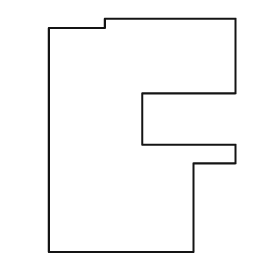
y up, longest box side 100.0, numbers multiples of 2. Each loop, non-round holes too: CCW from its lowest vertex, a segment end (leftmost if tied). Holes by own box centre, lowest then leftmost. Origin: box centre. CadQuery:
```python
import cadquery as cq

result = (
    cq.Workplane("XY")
    .moveTo(-40.0, -50.0)
    .lineTo(22.0, -50.0)
    .lineTo(22.0, -12.0)
    .lineTo(40.0, -12.0)
    .lineTo(40.0, -4.0)
    .lineTo(0.0, -4.0)
    .lineTo(0.0, 18.0)
    .lineTo(40.0, 18.0)
    .lineTo(40.0, 50.0)
    .lineTo(-16.0, 50.0)
    .lineTo(-16.0, 46.0)
    .lineTo(-40.0, 46.0)
    .close()
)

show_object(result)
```